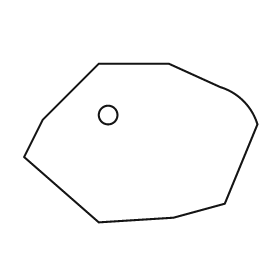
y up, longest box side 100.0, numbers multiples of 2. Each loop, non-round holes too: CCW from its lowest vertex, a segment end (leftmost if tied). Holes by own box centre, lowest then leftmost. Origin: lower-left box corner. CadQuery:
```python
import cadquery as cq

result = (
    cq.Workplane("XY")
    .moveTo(32.0, 0.0)
    .lineTo(64.0, 2.0)
    .lineTo(86.0, 8.0)
    .lineTo(100.0, 42.0)
    .threePointArc((94.0, 52.0), (84.0, 58.0))
    .lineTo(62.0, 68.0)
    .lineTo(32.0, 68.0)
    .lineTo(8.0, 44.0)
    .lineTo(0.0, 28.0)
    .close()
    .moveTo(36.0, 46.0)
    .circle(4.0)
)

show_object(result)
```